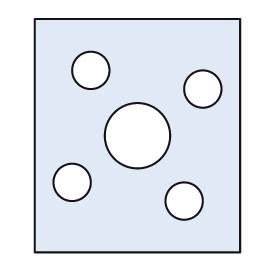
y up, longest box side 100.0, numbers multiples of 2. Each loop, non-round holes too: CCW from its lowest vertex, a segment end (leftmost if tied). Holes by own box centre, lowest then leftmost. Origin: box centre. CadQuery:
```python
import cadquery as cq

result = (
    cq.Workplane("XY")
    .moveTo(-44.0, -50.0)
    .lineTo(44.0, -50.0)
    .lineTo(44.0, 50.0)
    .lineTo(-44.0, 50.0)
    .close()
    .moveTo(20.0, -28.0)
    .circle(8.0)
    .moveTo(-28.0, -20.0)
    .circle(8.0)
    .moveTo(0.0, 0.0)
    .circle(14.0)
    .moveTo(28.0, 20.0)
    .circle(8.0)
    .moveTo(-20.0, 28.0)
    .circle(8.0)
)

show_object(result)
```